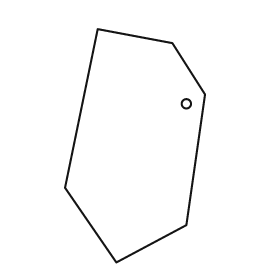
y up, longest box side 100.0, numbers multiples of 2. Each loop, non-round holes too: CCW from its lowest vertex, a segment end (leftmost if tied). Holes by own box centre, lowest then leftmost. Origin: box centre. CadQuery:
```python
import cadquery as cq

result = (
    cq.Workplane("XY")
    .moveTo(-8.0, -50.0)
    .lineTo(22.0, -34.0)
    .lineTo(30.0, 22.0)
    .lineTo(16.0, 44.0)
    .lineTo(-16.0, 50.0)
    .lineTo(-30.0, -18.0)
    .close()
    .moveTo(22.0, 18.0)
    .circle(2.0)
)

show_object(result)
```